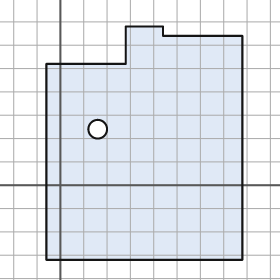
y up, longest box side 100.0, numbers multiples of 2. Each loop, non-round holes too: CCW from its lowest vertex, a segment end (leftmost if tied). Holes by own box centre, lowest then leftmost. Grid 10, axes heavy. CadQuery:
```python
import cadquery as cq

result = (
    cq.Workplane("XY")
    .moveTo(-6.0, -32.0)
    .lineTo(78.0, -32.0)
    .lineTo(78.0, 64.0)
    .lineTo(44.0, 64.0)
    .lineTo(44.0, 68.0)
    .lineTo(28.0, 68.0)
    .lineTo(28.0, 52.0)
    .lineTo(-6.0, 52.0)
    .close()
    .moveTo(16.0, 24.0)
    .circle(4.0)
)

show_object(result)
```